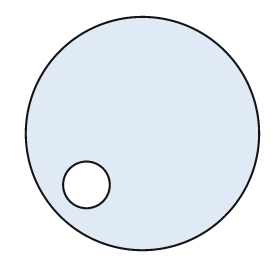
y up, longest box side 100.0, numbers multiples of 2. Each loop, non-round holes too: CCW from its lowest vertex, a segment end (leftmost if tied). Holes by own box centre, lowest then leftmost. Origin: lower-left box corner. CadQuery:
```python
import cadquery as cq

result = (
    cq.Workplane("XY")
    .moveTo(50.0, 50.0)
    .circle(50.0)
    .moveTo(26.0, 28.0)
    .circle(10.0)
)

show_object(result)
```